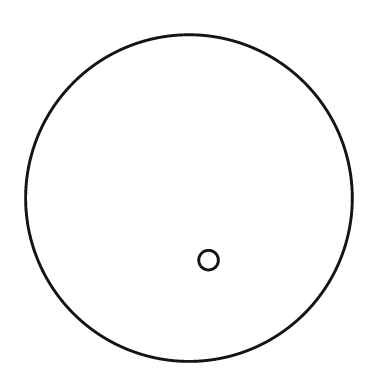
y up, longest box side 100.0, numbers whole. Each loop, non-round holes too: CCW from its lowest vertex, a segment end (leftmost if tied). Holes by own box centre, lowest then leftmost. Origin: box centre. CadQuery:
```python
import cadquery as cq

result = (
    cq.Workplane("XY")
    .moveTo(0.0, 0.0)
    .circle(50.0)
    .moveTo(6.0, -19.0)
    .circle(3.0)
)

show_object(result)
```